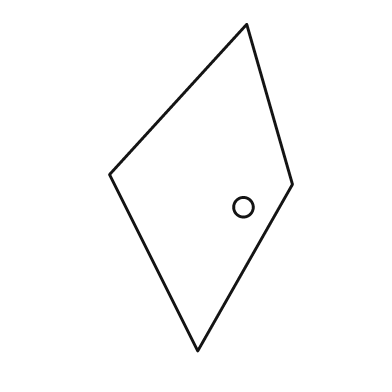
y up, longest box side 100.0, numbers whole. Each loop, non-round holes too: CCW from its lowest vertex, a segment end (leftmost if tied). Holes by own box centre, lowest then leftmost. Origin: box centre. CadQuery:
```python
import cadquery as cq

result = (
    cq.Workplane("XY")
    .moveTo(-1.0, -50.0)
    .lineTo(28.0, 1.0)
    .lineTo(14.0, 50.0)
    .lineTo(-28.0, 4.0)
    .close()
    .moveTo(13.0, -6.0)
    .circle(3.0)
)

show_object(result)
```